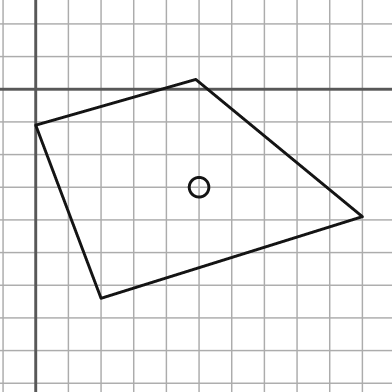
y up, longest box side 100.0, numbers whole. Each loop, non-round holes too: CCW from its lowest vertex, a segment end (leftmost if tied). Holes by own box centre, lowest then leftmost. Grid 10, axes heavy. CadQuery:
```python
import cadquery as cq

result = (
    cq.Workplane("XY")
    .moveTo(20.0, -64.0)
    .lineTo(100.0, -39.0)
    .lineTo(49.0, 3.0)
    .lineTo(0.0, -11.0)
    .close()
    .moveTo(50.0, -30.0)
    .circle(3.0)
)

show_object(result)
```